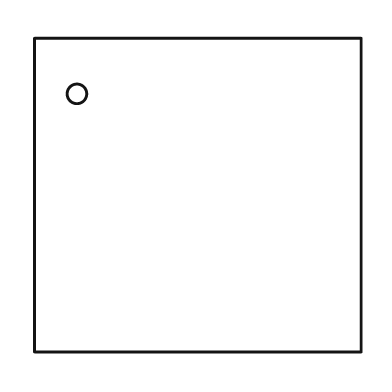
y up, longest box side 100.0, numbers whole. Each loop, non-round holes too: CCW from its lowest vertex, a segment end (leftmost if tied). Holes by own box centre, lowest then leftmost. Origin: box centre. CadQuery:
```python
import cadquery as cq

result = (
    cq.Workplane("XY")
    .moveTo(-50.0, -48.0)
    .lineTo(50.0, -48.0)
    .lineTo(50.0, 48.0)
    .lineTo(-50.0, 48.0)
    .close()
    .moveTo(-37.0, 31.0)
    .circle(3.0)
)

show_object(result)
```